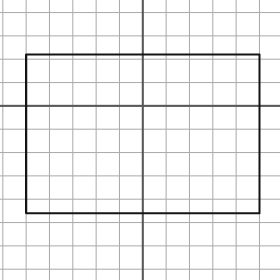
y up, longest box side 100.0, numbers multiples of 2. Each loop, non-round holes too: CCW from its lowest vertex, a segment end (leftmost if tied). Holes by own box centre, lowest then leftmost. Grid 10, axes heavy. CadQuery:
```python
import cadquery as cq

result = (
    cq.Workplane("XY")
    .moveTo(-50.0, -46.0)
    .lineTo(50.0, -46.0)
    .lineTo(50.0, 22.0)
    .lineTo(-50.0, 22.0)
    .close()
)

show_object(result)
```